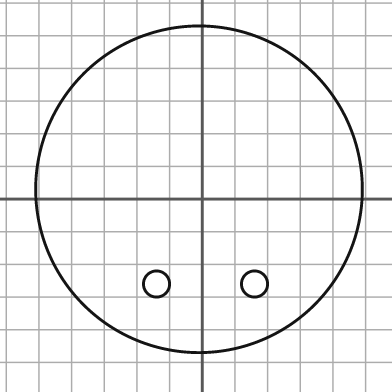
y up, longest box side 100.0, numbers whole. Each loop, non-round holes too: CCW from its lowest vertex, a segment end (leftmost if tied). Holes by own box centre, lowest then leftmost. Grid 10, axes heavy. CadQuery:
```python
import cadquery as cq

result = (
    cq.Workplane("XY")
    .moveTo(-1.0, 3.0)
    .circle(50.0)
    .moveTo(-14.0, -26.0)
    .circle(4.0)
    .moveTo(16.0, -26.0)
    .circle(4.0)
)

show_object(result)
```